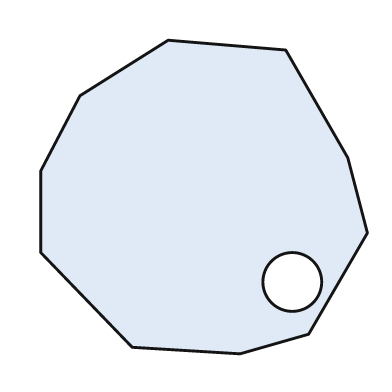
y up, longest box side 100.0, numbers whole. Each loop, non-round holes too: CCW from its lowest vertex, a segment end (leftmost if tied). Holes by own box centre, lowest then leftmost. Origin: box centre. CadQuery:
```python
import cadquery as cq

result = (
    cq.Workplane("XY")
    .moveTo(11.0, -48.0)
    .lineTo(32.0, -42.0)
    .lineTo(50.0, -11.0)
    .lineTo(44.0, 12.0)
    .lineTo(25.0, 45.0)
    .lineTo(-11.0, 48.0)
    .lineTo(-38.0, 31.0)
    .lineTo(-50.0, 8.0)
    .lineTo(-50.0, -17.0)
    .lineTo(-22.0, -46.0)
    .close()
    .moveTo(27.0, -26.0)
    .circle(9.0)
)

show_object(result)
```